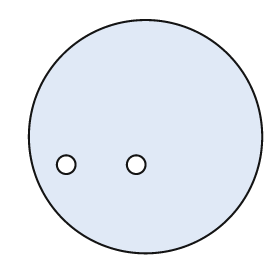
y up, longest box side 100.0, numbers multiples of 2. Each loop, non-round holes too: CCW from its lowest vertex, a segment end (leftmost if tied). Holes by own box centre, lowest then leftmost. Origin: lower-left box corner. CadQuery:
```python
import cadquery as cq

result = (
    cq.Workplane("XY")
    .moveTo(50.0, 50.0)
    .circle(50.0)
    .moveTo(16.0, 38.0)
    .circle(4.0)
    .moveTo(46.0, 38.0)
    .circle(4.0)
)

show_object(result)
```